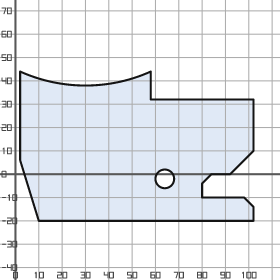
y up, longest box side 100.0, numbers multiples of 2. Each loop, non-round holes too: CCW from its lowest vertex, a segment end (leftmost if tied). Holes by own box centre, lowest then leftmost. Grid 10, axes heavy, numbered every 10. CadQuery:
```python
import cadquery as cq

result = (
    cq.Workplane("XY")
    .moveTo(10.0, -20.0)
    .lineTo(102.0, -20.0)
    .lineTo(102.0, -14.0)
    .lineTo(98.0, -10.0)
    .lineTo(80.0, -10.0)
    .lineTo(80.0, -4.0)
    .lineTo(84.0, 0.0)
    .lineTo(92.0, 0.0)
    .lineTo(102.0, 10.0)
    .lineTo(102.0, 32.0)
    .lineTo(58.0, 32.0)
    .lineTo(58.0, 44.0)
    .threePointArc((30.0, 38.0), (2.0, 44.0))
    .lineTo(2.0, 6.0)
    .close()
    .moveTo(64.0, -2.0)
    .circle(4.0)
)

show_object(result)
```